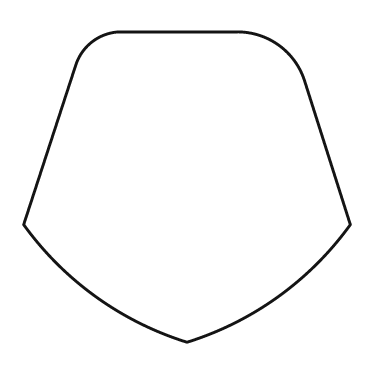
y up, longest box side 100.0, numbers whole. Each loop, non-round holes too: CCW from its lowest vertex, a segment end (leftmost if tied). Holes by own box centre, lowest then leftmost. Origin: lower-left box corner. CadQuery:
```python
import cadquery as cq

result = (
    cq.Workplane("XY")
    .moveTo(50.0, 0.0)
    .threePointArc((78.0, 14.0), (100.0, 36.0))
    .lineTo(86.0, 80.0)
    .threePointArc((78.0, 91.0), (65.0, 95.0))
    .lineTo(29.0, 95.0)
    .threePointArc((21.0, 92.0), (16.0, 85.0))
    .lineTo(0.0, 36.0)
    .threePointArc((22.0, 14.0), (50.0, 0.0))
    .close()
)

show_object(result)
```